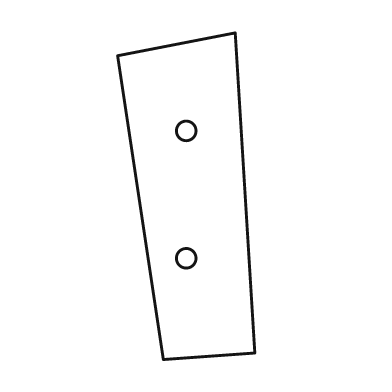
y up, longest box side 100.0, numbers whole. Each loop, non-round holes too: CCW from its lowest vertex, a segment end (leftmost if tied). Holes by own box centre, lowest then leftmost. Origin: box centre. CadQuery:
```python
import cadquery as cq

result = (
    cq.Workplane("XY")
    .moveTo(-7.0, -50.0)
    .lineTo(21.0, -48.0)
    .lineTo(15.0, 50.0)
    .lineTo(-21.0, 43.0)
    .close()
    .moveTo(0.0, -19.0)
    .circle(3.0)
    .moveTo(0.0, 20.0)
    .circle(3.0)
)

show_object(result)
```